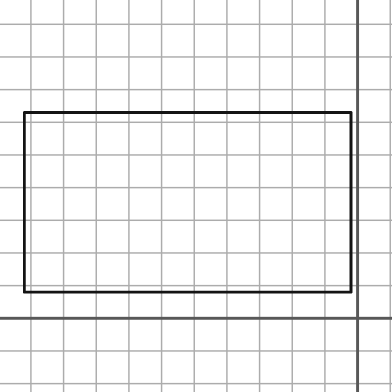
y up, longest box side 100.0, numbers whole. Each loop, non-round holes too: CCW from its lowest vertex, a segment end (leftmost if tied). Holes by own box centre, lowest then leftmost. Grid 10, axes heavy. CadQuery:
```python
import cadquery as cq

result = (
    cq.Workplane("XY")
    .moveTo(-102.0, 8.0)
    .lineTo(-2.0, 8.0)
    .lineTo(-2.0, 63.0)
    .lineTo(-102.0, 63.0)
    .close()
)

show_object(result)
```